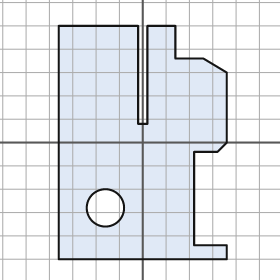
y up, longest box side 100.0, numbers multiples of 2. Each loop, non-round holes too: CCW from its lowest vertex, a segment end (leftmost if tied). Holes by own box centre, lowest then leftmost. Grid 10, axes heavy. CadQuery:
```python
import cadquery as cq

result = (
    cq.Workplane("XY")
    .moveTo(-36.0, -50.0)
    .lineTo(36.0, -50.0)
    .lineTo(36.0, -44.0)
    .lineTo(22.0, -44.0)
    .lineTo(22.0, -4.0)
    .lineTo(32.0, -4.0)
    .lineTo(36.0, 0.0)
    .lineTo(36.0, 30.0)
    .lineTo(26.0, 36.0)
    .lineTo(14.0, 36.0)
    .lineTo(14.0, 50.0)
    .lineTo(2.0, 50.0)
    .lineTo(2.0, 8.0)
    .lineTo(-2.0, 8.0)
    .lineTo(-2.0, 50.0)
    .lineTo(-36.0, 50.0)
    .close()
    .moveTo(-16.0, -28.0)
    .circle(8.0)
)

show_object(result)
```